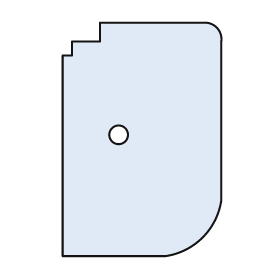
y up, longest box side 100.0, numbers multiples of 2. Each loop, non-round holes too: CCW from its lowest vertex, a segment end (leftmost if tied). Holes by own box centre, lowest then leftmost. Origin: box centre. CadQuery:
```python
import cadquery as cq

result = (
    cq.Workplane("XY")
    .moveTo(-34.0, -50.0)
    .lineTo(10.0, -50.0)
    .threePointArc((26.0, -42.0), (34.0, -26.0))
    .lineTo(34.0, 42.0)
    .threePointArc((32.0, 48.0), (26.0, 50.0))
    .lineTo(-18.0, 50.0)
    .lineTo(-18.0, 42.0)
    .lineTo(-30.0, 42.0)
    .lineTo(-30.0, 36.0)
    .lineTo(-34.0, 36.0)
    .close()
    .moveTo(-10.0, 2.0)
    .circle(4.0)
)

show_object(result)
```